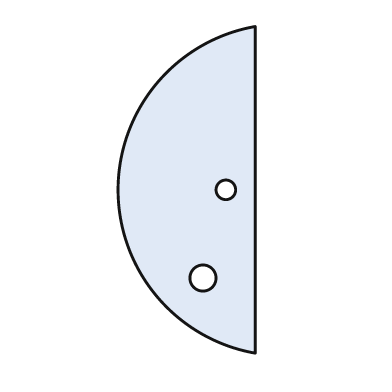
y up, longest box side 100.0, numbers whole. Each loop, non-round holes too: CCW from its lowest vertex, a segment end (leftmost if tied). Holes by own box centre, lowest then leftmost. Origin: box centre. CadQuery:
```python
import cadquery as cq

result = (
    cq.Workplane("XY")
    .moveTo(21.0, -50.0)
    .lineTo(21.0, 50.0)
    .threePointArc((-21.0, 0.0), (21.0, -50.0))
    .close()
    .moveTo(5.0, -27.0)
    .circle(4.0)
    .moveTo(12.0, 0.0)
    .circle(3.0)
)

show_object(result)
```